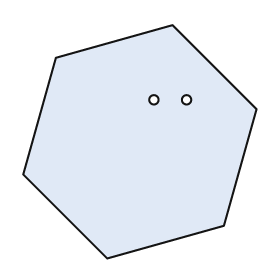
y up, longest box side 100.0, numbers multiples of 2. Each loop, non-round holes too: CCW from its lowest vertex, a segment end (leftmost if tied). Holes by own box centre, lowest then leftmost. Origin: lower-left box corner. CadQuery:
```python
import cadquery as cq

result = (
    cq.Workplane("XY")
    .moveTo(36.0, 0.0)
    .lineTo(86.0, 14.0)
    .lineTo(100.0, 64.0)
    .lineTo(64.0, 100.0)
    .lineTo(14.0, 86.0)
    .lineTo(0.0, 36.0)
    .close()
    .moveTo(56.0, 68.0)
    .circle(2.0)
    .moveTo(70.0, 68.0)
    .circle(2.0)
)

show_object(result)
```